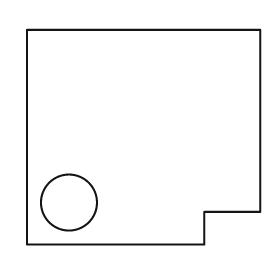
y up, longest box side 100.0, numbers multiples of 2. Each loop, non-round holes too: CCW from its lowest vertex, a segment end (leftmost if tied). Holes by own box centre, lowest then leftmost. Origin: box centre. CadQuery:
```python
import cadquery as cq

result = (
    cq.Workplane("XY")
    .moveTo(-50.0, -46.0)
    .lineTo(26.0, -46.0)
    .lineTo(26.0, -32.0)
    .lineTo(50.0, -32.0)
    .lineTo(50.0, 46.0)
    .lineTo(-50.0, 46.0)
    .close()
    .moveTo(-32.0, -28.0)
    .circle(12.0)
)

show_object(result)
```